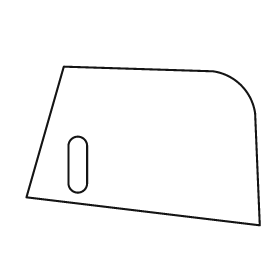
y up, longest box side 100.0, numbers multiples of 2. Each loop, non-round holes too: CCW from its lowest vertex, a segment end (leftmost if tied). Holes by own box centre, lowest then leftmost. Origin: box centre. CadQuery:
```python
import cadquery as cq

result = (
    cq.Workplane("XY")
    .moveTo(50.0, -34.0)
    .lineTo(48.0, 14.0)
    .threePointArc((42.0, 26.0), (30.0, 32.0))
    .lineTo(-34.0, 34.0)
    .lineTo(-50.0, -22.0)
    .close()
    .moveTo(-32.0, -16.0)
    .threePointArc((-28.0, -20.0), (-24.0, -16.0))
    .lineTo(-24.0, 0.0)
    .threePointArc((-28.0, 4.0), (-32.0, 0.0))
    .close()
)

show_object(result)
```